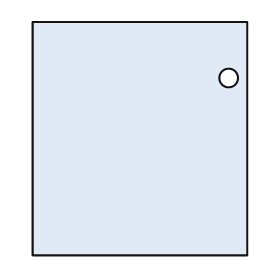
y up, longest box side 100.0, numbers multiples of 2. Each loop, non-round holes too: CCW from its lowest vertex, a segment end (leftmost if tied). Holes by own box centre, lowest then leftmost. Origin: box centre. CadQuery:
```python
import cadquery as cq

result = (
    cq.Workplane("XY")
    .moveTo(-46.0, -50.0)
    .lineTo(46.0, -50.0)
    .lineTo(46.0, 50.0)
    .lineTo(-46.0, 50.0)
    .close()
    .moveTo(38.0, 26.0)
    .circle(4.0)
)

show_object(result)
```